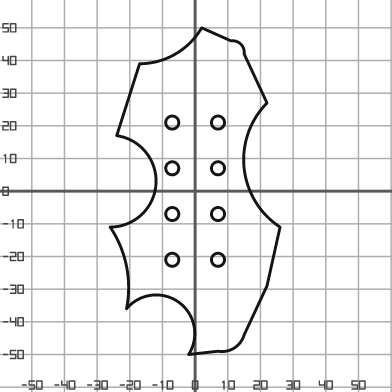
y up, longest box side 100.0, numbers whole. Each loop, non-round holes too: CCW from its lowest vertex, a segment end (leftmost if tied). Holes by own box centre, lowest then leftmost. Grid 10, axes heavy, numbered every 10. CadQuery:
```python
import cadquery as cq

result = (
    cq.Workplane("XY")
    .moveTo(-2.0, -50.0)
    .lineTo(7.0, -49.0)
    .threePointArc((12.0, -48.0), (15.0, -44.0))
    .lineTo(22.0, -29.0)
    .lineTo(26.0, -11.0)
    .threePointArc((15.0, 7.0), (22.0, 27.0))
    .lineTo(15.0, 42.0)
    .threePointArc((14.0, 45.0), (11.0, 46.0))
    .lineTo(2.0, 50.0)
    .threePointArc((-6.0, 42.0), (-17.0, 39.0))
    .lineTo(-24.0, 17.0)
    .threePointArc((-12.0, 2.0), (-26.0, -11.0))
    .threePointArc((-21.0, -23.0), (-21.0, -36.0))
    .threePointArc((-5.0, -34.0), (-2.0, -50.0))
    .close()
    .moveTo(-7.0, -21.0)
    .circle(2.0)
    .moveTo(7.0, -21.0)
    .circle(2.0)
    .moveTo(-7.0, -7.0)
    .circle(2.0)
    .moveTo(7.0, -7.0)
    .circle(2.0)
    .moveTo(-7.0, 7.0)
    .circle(2.0)
    .moveTo(7.0, 7.0)
    .circle(2.0)
    .moveTo(-7.0, 21.0)
    .circle(2.0)
    .moveTo(7.0, 21.0)
    .circle(2.0)
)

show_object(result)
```